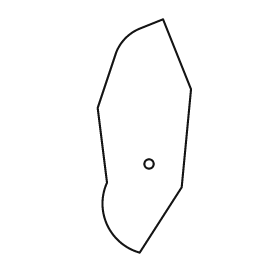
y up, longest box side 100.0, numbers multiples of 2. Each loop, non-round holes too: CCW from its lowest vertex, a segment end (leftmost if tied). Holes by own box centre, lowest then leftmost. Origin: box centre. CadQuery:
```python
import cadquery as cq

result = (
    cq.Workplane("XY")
    .moveTo(-2.0, -50.0)
    .lineTo(16.0, -22.0)
    .lineTo(20.0, 20.0)
    .lineTo(8.0, 50.0)
    .lineTo(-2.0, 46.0)
    .threePointArc((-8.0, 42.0), (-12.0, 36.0))
    .lineTo(-20.0, 12.0)
    .lineTo(-16.0, -20.0)
    .threePointArc((-16.0, -38.0), (-2.0, -50.0))
    .close()
    .moveTo(2.0, -12.0)
    .circle(2.0)
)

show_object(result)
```